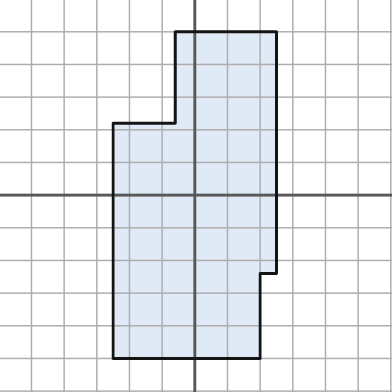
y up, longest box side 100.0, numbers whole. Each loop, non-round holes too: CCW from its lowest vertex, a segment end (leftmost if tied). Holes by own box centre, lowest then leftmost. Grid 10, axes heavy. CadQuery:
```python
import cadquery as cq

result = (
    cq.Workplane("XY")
    .moveTo(-25.0, -50.0)
    .lineTo(20.0, -50.0)
    .lineTo(20.0, -24.0)
    .lineTo(25.0, -24.0)
    .lineTo(25.0, 50.0)
    .lineTo(-6.0, 50.0)
    .lineTo(-6.0, 22.0)
    .lineTo(-25.0, 22.0)
    .close()
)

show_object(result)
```